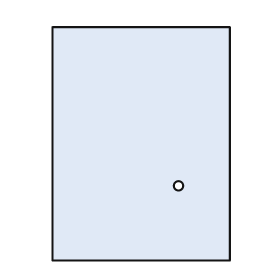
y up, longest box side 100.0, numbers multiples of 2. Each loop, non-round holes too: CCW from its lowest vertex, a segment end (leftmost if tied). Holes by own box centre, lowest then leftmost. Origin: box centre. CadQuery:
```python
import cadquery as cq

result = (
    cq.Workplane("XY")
    .moveTo(-38.0, -50.0)
    .lineTo(38.0, -50.0)
    .lineTo(38.0, 50.0)
    .lineTo(-38.0, 50.0)
    .close()
    .moveTo(16.0, -18.0)
    .circle(2.0)
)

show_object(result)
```